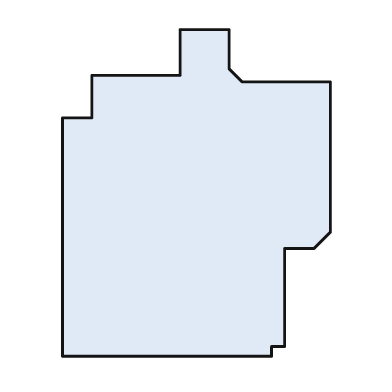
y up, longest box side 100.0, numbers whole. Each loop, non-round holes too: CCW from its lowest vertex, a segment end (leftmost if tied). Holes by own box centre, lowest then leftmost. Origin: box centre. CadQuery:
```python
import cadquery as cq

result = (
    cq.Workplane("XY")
    .moveTo(-41.0, -50.0)
    .lineTo(23.0, -50.0)
    .lineTo(23.0, -47.0)
    .lineTo(27.0, -47.0)
    .lineTo(27.0, -17.0)
    .lineTo(36.0, -17.0)
    .lineTo(41.0, -12.0)
    .lineTo(41.0, 34.0)
    .lineTo(14.0, 34.0)
    .lineTo(10.0, 38.0)
    .lineTo(10.0, 50.0)
    .lineTo(-5.0, 50.0)
    .lineTo(-5.0, 36.0)
    .lineTo(-32.0, 36.0)
    .lineTo(-32.0, 23.0)
    .lineTo(-41.0, 23.0)
    .close()
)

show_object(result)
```